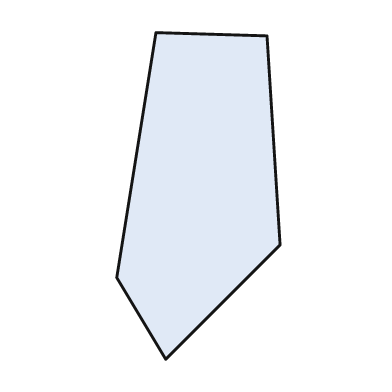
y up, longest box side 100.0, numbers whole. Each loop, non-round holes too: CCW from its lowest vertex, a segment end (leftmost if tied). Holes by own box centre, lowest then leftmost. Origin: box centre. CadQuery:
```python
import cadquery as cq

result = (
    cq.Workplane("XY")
    .moveTo(-10.0, -50.0)
    .lineTo(25.0, -15.0)
    .lineTo(21.0, 49.0)
    .lineTo(-13.0, 50.0)
    .lineTo(-25.0, -25.0)
    .close()
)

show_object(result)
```